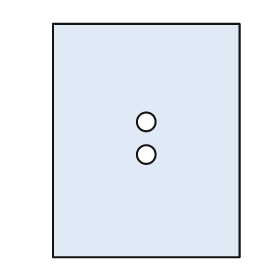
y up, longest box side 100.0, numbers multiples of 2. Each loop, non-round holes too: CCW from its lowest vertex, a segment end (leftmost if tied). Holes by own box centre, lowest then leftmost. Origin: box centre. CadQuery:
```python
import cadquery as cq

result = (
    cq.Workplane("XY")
    .moveTo(-40.0, -50.0)
    .lineTo(40.0, -50.0)
    .lineTo(40.0, 50.0)
    .lineTo(-40.0, 50.0)
    .close()
    .moveTo(0.0, -6.0)
    .circle(4.0)
    .moveTo(0.0, 8.0)
    .circle(4.0)
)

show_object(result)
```